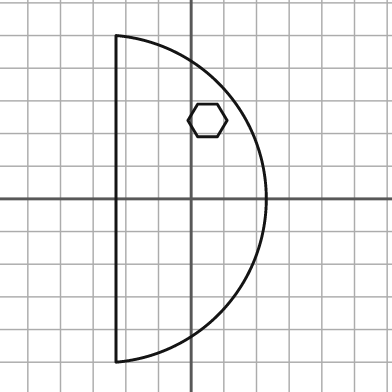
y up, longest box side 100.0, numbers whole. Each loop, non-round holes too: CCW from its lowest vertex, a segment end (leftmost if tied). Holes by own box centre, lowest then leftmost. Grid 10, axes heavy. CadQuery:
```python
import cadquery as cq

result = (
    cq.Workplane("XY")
    .moveTo(-23.0, -50.0)
    .threePointArc((23.0, 0.0), (-23.0, 50.0))
    .close()
    .moveTo(2.0, 19.0)
    .lineTo(8.0, 19.0)
    .lineTo(11.0, 24.0)
    .lineTo(8.0, 29.0)
    .lineTo(2.0, 29.0)
    .lineTo(-1.0, 24.0)
    .close()
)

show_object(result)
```